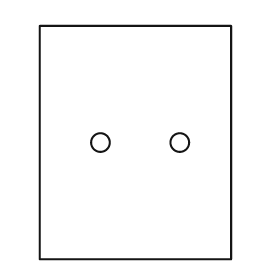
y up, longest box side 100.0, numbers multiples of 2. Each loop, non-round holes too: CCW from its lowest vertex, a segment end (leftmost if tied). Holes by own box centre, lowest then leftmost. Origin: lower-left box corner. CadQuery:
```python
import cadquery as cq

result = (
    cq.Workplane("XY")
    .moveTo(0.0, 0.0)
    .lineTo(82.0, 0.0)
    .lineTo(82.0, 100.0)
    .lineTo(0.0, 100.0)
    .close()
    .moveTo(26.0, 50.0)
    .circle(4.0)
    .moveTo(60.0, 50.0)
    .circle(4.0)
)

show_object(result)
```